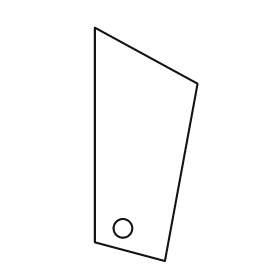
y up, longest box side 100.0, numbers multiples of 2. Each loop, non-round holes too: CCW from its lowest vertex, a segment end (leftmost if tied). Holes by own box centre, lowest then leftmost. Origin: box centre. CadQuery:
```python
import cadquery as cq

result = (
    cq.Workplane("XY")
    .moveTo(8.0, -50.0)
    .lineTo(22.0, 26.0)
    .lineTo(-22.0, 50.0)
    .lineTo(-22.0, -42.0)
    .close()
    .moveTo(-10.0, -36.0)
    .circle(4.0)
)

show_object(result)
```